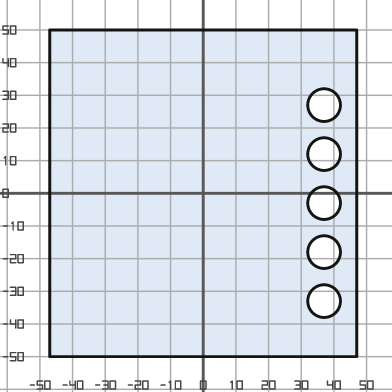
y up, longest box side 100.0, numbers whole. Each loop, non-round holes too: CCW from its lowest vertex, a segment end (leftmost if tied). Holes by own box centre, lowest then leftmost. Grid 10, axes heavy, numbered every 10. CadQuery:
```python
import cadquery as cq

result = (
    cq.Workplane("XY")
    .moveTo(-47.0, -50.0)
    .lineTo(47.0, -50.0)
    .lineTo(47.0, 50.0)
    .lineTo(-47.0, 50.0)
    .close()
    .moveTo(37.0, -33.0)
    .circle(5.0)
    .moveTo(37.0, -18.0)
    .circle(5.0)
    .moveTo(37.0, -3.0)
    .circle(5.0)
    .moveTo(37.0, 12.0)
    .circle(5.0)
    .moveTo(37.0, 27.0)
    .circle(5.0)
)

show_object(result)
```